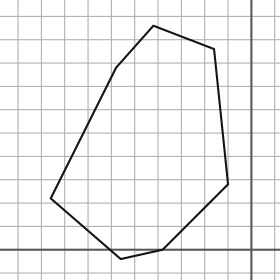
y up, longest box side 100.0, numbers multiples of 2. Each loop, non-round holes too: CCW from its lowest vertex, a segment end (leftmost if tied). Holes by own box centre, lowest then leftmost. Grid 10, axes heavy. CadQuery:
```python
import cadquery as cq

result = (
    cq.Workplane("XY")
    .moveTo(-56.0, -4.0)
    .lineTo(-38.0, 0.0)
    .lineTo(-10.0, 28.0)
    .lineTo(-16.0, 86.0)
    .lineTo(-42.0, 96.0)
    .lineTo(-58.0, 78.0)
    .lineTo(-86.0, 22.0)
    .close()
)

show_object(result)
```